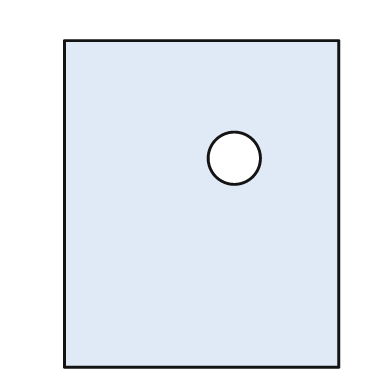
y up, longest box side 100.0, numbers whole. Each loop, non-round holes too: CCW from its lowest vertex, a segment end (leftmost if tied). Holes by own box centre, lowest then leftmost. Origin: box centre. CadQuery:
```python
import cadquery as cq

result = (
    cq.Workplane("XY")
    .moveTo(-42.0, -50.0)
    .lineTo(42.0, -50.0)
    .lineTo(42.0, 50.0)
    .lineTo(-42.0, 50.0)
    .close()
    .moveTo(10.0, 14.0)
    .circle(8.0)
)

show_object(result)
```